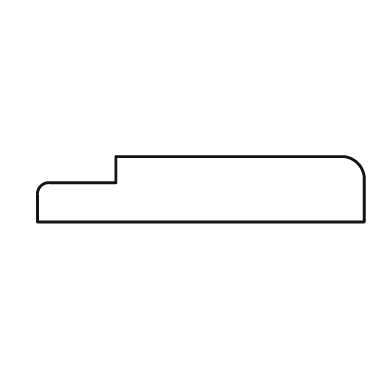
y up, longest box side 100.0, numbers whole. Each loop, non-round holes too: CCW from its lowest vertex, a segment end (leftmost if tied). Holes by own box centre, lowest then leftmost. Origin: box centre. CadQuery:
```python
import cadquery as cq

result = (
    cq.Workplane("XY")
    .moveTo(-50.0, -10.0)
    .lineTo(50.0, -10.0)
    .lineTo(50.0, 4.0)
    .threePointArc((48.0, 8.0), (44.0, 10.0))
    .lineTo(-26.0, 10.0)
    .lineTo(-26.0, 2.0)
    .lineTo(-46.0, 2.0)
    .threePointArc((-49.0, 1.0), (-50.0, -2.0))
    .close()
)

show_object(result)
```